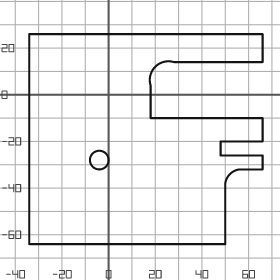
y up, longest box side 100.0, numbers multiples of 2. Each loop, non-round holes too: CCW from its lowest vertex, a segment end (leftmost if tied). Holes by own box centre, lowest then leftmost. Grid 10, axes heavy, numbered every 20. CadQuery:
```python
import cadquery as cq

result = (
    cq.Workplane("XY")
    .moveTo(-34.0, -64.0)
    .lineTo(50.0, -64.0)
    .lineTo(50.0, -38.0)
    .threePointArc((52.0, -34.0), (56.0, -32.0))
    .lineTo(66.0, -32.0)
    .lineTo(66.0, -26.0)
    .lineTo(48.0, -26.0)
    .lineTo(48.0, -20.0)
    .lineTo(66.0, -20.0)
    .lineTo(66.0, -10.0)
    .lineTo(18.0, -10.0)
    .lineTo(18.0, 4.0)
    .threePointArc((20.0, 12.0), (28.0, 14.0))
    .lineTo(66.0, 14.0)
    .lineTo(66.0, 26.0)
    .lineTo(-34.0, 26.0)
    .close()
    .moveTo(-4.0, -28.0)
    .circle(4.0)
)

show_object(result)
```